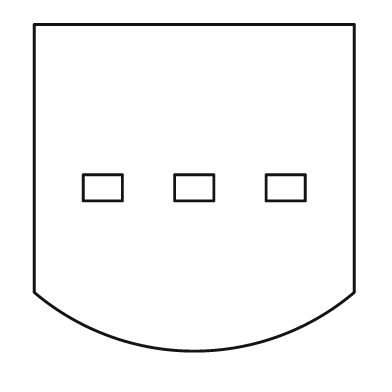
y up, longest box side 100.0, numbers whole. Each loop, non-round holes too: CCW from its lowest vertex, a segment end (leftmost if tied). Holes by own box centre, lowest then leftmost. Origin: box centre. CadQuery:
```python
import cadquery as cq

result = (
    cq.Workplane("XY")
    .moveTo(-49.0, -32.0)
    .threePointArc((0.0, -50.0), (49.0, -32.0))
    .lineTo(49.0, 50.0)
    .lineTo(-49.0, 50.0)
    .close()
    .moveTo(-34.0, -4.0)
    .lineTo(-22.0, -4.0)
    .lineTo(-22.0, 4.0)
    .lineTo(-34.0, 4.0)
    .close()
    .moveTo(-6.0, -4.0)
    .lineTo(6.0, -4.0)
    .lineTo(6.0, 4.0)
    .lineTo(-6.0, 4.0)
    .close()
    .moveTo(22.0, -4.0)
    .lineTo(34.0, -4.0)
    .lineTo(34.0, 4.0)
    .lineTo(22.0, 4.0)
    .close()
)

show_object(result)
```